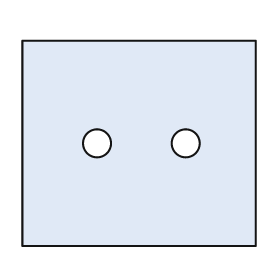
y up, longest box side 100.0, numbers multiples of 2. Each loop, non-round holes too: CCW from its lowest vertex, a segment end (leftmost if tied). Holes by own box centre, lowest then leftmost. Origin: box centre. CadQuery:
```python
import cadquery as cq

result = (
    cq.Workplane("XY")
    .moveTo(-50.0, -44.0)
    .lineTo(50.0, -44.0)
    .lineTo(50.0, 44.0)
    .lineTo(-50.0, 44.0)
    .close()
    .moveTo(-18.0, 0.0)
    .circle(6.0)
    .moveTo(20.0, 0.0)
    .circle(6.0)
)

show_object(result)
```